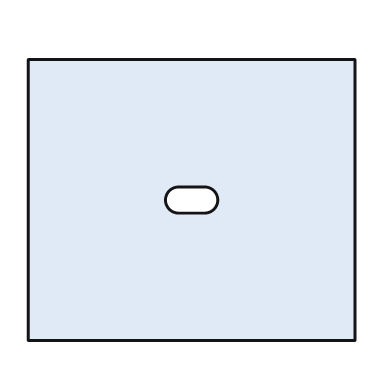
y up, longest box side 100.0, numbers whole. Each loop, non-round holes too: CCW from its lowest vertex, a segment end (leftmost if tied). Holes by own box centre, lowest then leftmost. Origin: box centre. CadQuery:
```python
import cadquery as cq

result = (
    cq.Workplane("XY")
    .moveTo(-50.0, -43.0)
    .lineTo(50.0, -43.0)
    .lineTo(50.0, 43.0)
    .lineTo(-50.0, 43.0)
    .close()
    .moveTo(-4.0, -4.0)
    .lineTo(4.0, -4.0)
    .threePointArc((8.0, 0.0), (4.0, 4.0))
    .lineTo(-4.0, 4.0)
    .threePointArc((-8.0, 0.0), (-4.0, -4.0))
    .close()
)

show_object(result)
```